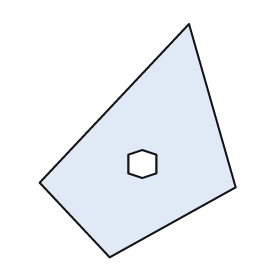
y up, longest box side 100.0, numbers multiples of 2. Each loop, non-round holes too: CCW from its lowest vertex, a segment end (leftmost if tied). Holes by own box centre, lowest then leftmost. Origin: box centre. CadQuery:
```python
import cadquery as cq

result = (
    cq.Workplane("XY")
    .moveTo(-12.0, -50.0)
    .lineTo(42.0, -20.0)
    .lineTo(22.0, 50.0)
    .lineTo(-42.0, -18.0)
    .close()
    .moveTo(2.0, -16.0)
    .lineTo(8.0, -14.0)
    .lineTo(8.0, -6.0)
    .lineTo(2.0, -4.0)
    .lineTo(-4.0, -6.0)
    .lineTo(-4.0, -14.0)
    .close()
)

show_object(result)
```